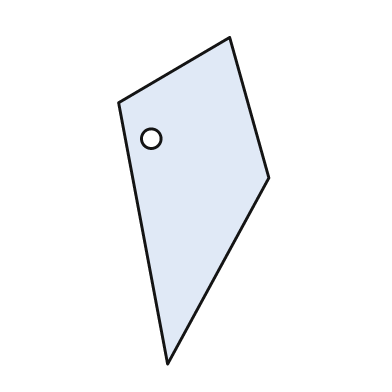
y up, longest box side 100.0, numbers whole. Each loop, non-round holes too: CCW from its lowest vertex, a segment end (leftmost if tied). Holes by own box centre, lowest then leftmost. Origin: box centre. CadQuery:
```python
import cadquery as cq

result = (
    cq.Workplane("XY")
    .moveTo(-8.0, -50.0)
    .lineTo(23.0, 7.0)
    .lineTo(11.0, 50.0)
    .lineTo(-23.0, 30.0)
    .close()
    .moveTo(-13.0, 19.0)
    .circle(3.0)
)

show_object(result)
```